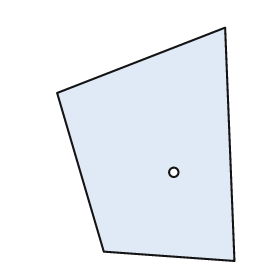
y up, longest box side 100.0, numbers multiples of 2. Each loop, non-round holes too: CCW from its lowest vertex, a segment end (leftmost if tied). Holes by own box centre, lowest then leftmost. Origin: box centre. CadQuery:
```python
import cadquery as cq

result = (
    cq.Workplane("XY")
    .moveTo(38.0, -50.0)
    .lineTo(34.0, 50.0)
    .lineTo(-38.0, 22.0)
    .lineTo(-18.0, -46.0)
    .close()
    .moveTo(12.0, -12.0)
    .circle(2.0)
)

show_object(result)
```